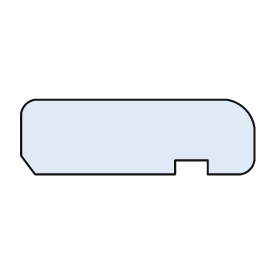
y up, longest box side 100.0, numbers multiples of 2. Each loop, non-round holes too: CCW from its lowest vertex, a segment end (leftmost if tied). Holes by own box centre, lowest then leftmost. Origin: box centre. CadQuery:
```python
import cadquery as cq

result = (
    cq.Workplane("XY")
    .moveTo(-44.0, -16.0)
    .lineTo(16.0, -16.0)
    .lineTo(16.0, -10.0)
    .lineTo(30.0, -10.0)
    .lineTo(30.0, -16.0)
    .lineTo(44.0, -16.0)
    .threePointArc((48.0, -14.0), (50.0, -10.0))
    .lineTo(50.0, 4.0)
    .threePointArc((46.0, 12.0), (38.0, 16.0))
    .lineTo(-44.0, 16.0)
    .threePointArc((-48.0, 14.0), (-50.0, 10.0))
    .lineTo(-50.0, -8.0)
    .close()
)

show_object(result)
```